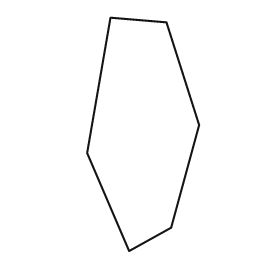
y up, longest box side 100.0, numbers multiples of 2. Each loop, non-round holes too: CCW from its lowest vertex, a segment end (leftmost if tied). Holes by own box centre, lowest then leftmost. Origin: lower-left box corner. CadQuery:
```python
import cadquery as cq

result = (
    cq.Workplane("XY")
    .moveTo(18.0, 0.0)
    .lineTo(36.0, 10.0)
    .lineTo(48.0, 54.0)
    .lineTo(34.0, 98.0)
    .lineTo(10.0, 100.0)
    .lineTo(0.0, 42.0)
    .close()
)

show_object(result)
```